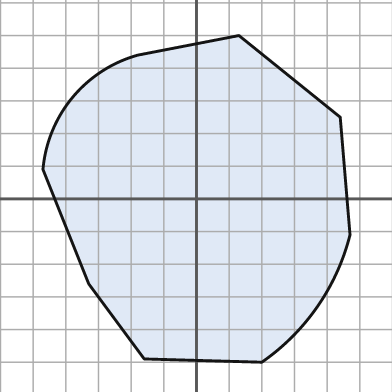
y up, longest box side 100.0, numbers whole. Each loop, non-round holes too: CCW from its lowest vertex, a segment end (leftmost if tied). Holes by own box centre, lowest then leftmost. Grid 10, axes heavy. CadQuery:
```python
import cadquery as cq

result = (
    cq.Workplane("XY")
    .moveTo(20.0, -50.0)
    .threePointArc((37.0, -33.0), (47.0, -11.0))
    .lineTo(44.0, 25.0)
    .lineTo(13.0, 50.0)
    .lineTo(-18.0, 44.0)
    .threePointArc((-38.0, 31.0), (-47.0, 9.0))
    .lineTo(-33.0, -26.0)
    .lineTo(-16.0, -49.0)
    .close()
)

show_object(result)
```